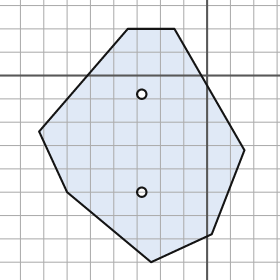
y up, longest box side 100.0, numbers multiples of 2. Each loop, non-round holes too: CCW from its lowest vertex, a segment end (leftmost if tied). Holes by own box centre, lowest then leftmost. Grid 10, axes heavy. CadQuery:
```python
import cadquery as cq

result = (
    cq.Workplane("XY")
    .moveTo(-24.0, -80.0)
    .lineTo(2.0, -68.0)
    .lineTo(16.0, -32.0)
    .lineTo(-14.0, 20.0)
    .lineTo(-34.0, 20.0)
    .lineTo(-72.0, -24.0)
    .lineTo(-60.0, -50.0)
    .close()
    .moveTo(-28.0, -50.0)
    .circle(2.0)
    .moveTo(-28.0, -8.0)
    .circle(2.0)
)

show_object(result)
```